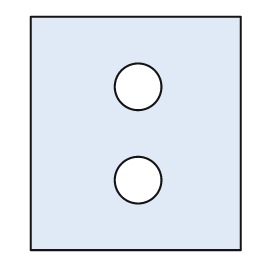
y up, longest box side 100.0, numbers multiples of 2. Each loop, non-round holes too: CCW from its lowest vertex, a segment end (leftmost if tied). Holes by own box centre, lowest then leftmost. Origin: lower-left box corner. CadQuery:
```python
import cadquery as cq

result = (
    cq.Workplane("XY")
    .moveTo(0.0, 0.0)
    .lineTo(90.0, 0.0)
    .lineTo(90.0, 100.0)
    .lineTo(0.0, 100.0)
    .close()
    .moveTo(46.0, 30.0)
    .circle(10.0)
    .moveTo(46.0, 70.0)
    .circle(10.0)
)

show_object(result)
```